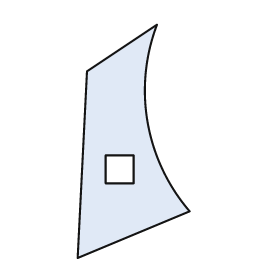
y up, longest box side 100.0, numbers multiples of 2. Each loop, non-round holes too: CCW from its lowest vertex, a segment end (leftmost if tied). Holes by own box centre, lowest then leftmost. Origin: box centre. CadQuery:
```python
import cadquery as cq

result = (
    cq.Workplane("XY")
    .moveTo(-24.0, -50.0)
    .lineTo(24.0, -30.0)
    .threePointArc((6.0, 8.0), (10.0, 50.0))
    .lineTo(-20.0, 30.0)
    .close()
    .moveTo(-12.0, -18.0)
    .lineTo(0.0, -18.0)
    .lineTo(0.0, -6.0)
    .lineTo(-12.0, -6.0)
    .close()
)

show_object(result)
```